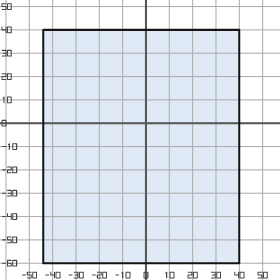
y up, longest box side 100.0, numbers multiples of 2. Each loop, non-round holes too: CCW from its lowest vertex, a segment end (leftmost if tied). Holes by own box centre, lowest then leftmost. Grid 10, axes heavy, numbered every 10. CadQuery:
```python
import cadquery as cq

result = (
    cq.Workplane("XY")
    .moveTo(-44.0, -60.0)
    .lineTo(40.0, -60.0)
    .lineTo(40.0, 40.0)
    .lineTo(-44.0, 40.0)
    .close()
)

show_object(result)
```